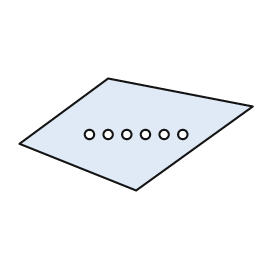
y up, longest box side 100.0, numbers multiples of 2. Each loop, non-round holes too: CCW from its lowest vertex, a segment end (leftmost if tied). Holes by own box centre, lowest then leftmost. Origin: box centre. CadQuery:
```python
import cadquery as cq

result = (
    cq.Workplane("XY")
    .moveTo(0.0, -24.0)
    .lineTo(50.0, 12.0)
    .lineTo(-12.0, 24.0)
    .lineTo(-50.0, -4.0)
    .close()
    .moveTo(-20.0, 0.0)
    .circle(2.0)
    .moveTo(-12.0, 0.0)
    .circle(2.0)
    .moveTo(-4.0, 0.0)
    .circle(2.0)
    .moveTo(4.0, 0.0)
    .circle(2.0)
    .moveTo(12.0, 0.0)
    .circle(2.0)
    .moveTo(20.0, 0.0)
    .circle(2.0)
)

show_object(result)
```